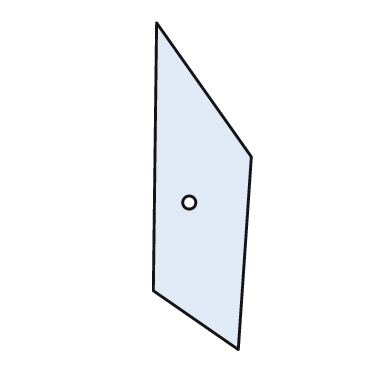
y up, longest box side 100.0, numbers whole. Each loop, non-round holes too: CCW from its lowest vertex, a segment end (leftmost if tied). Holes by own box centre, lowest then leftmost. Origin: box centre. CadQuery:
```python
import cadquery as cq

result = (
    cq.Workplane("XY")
    .moveTo(11.0, -50.0)
    .lineTo(15.0, 9.0)
    .lineTo(-14.0, 50.0)
    .lineTo(-15.0, -32.0)
    .close()
    .moveTo(-4.0, -5.0)
    .circle(2.0)
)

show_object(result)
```